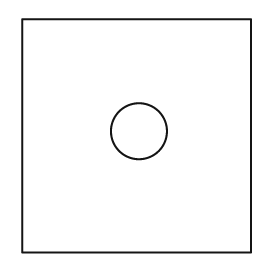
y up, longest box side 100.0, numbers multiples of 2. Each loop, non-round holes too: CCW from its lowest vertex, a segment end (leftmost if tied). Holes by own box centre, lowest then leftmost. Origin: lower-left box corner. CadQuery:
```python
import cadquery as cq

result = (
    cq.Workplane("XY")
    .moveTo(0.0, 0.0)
    .lineTo(98.0, 0.0)
    .lineTo(98.0, 100.0)
    .lineTo(0.0, 100.0)
    .close()
    .moveTo(50.0, 52.0)
    .circle(12.0)
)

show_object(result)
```